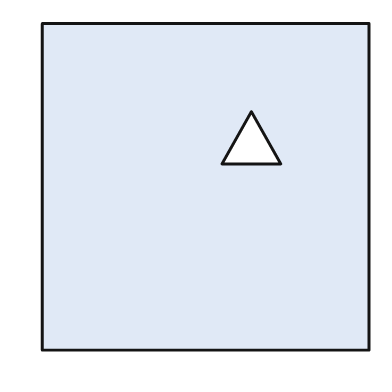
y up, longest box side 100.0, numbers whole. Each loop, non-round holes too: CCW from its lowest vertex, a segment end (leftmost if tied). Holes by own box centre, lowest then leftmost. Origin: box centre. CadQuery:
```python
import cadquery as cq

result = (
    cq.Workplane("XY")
    .moveTo(-50.0, -50.0)
    .lineTo(50.0, -50.0)
    .lineTo(50.0, 50.0)
    .lineTo(-50.0, 50.0)
    .close()
    .moveTo(5.0, 7.0)
    .lineTo(23.0, 7.0)
    .lineTo(14.0, 23.0)
    .close()
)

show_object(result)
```